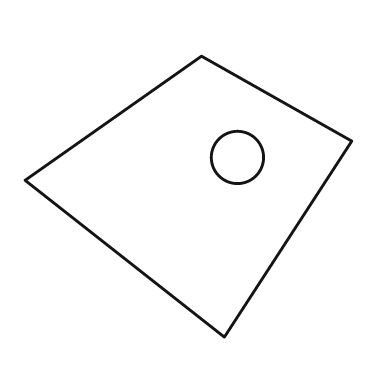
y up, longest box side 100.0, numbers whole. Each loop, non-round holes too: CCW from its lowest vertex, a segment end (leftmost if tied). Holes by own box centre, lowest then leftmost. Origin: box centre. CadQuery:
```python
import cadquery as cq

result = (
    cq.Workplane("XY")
    .moveTo(11.0, -43.0)
    .lineTo(50.0, 17.0)
    .lineTo(4.0, 43.0)
    .lineTo(-50.0, 5.0)
    .close()
    .moveTo(15.0, 12.0)
    .circle(8.0)
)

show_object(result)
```